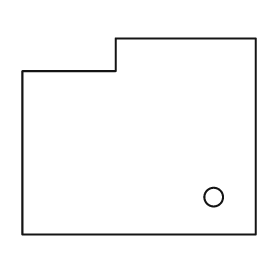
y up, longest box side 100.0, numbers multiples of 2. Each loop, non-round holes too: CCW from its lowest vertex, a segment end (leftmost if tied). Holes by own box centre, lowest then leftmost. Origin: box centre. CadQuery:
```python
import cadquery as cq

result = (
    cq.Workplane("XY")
    .moveTo(-50.0, -42.0)
    .lineTo(50.0, -42.0)
    .lineTo(50.0, 42.0)
    .lineTo(-10.0, 42.0)
    .lineTo(-10.0, 28.0)
    .lineTo(-50.0, 28.0)
    .close()
    .moveTo(32.0, -26.0)
    .circle(4.0)
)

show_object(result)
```